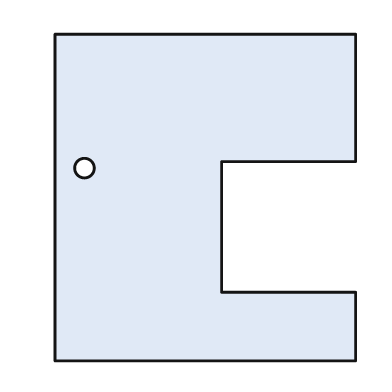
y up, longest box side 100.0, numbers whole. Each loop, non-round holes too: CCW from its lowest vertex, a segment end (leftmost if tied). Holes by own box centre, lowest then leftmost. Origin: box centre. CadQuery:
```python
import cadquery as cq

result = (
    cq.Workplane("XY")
    .moveTo(-46.0, -50.0)
    .lineTo(46.0, -50.0)
    .lineTo(46.0, -29.0)
    .lineTo(5.0, -29.0)
    .lineTo(5.0, 11.0)
    .lineTo(46.0, 11.0)
    .lineTo(46.0, 50.0)
    .lineTo(-46.0, 50.0)
    .close()
    .moveTo(-37.0, 9.0)
    .circle(3.0)
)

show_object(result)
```